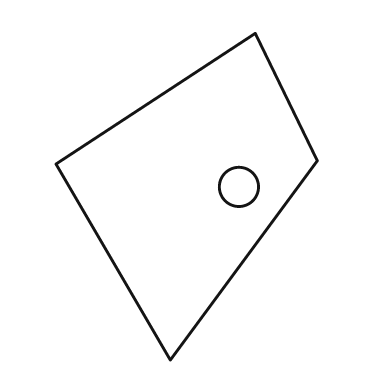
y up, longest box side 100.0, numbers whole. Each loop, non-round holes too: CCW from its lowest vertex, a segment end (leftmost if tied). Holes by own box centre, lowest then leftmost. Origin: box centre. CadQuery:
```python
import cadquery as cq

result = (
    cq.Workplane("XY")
    .moveTo(-5.0, -50.0)
    .lineTo(40.0, 11.0)
    .lineTo(21.0, 50.0)
    .lineTo(-40.0, 10.0)
    .close()
    .moveTo(16.0, 3.0)
    .circle(6.0)
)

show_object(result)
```